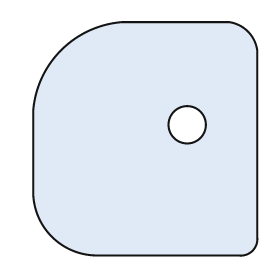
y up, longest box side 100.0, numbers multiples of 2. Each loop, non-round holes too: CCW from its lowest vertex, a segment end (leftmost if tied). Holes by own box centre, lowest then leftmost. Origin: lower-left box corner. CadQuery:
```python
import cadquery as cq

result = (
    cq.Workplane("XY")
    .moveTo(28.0, 0.0)
    .lineTo(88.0, 0.0)
    .threePointArc((94.0, 2.0), (96.0, 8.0))
    .lineTo(96.0, 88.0)
    .threePointArc((92.0, 96.0), (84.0, 100.0))
    .lineTo(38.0, 100.0)
    .threePointArc((12.0, 88.0), (0.0, 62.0))
    .lineTo(0.0, 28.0)
    .threePointArc((8.0, 8.0), (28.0, 0.0))
    .close()
    .moveTo(66.0, 56.0)
    .circle(8.0)
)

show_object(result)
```